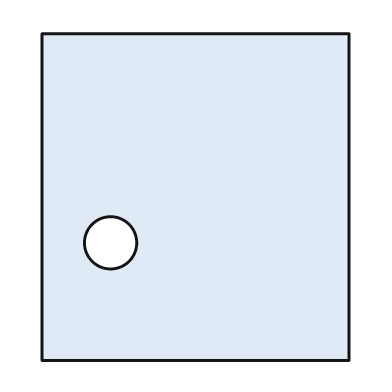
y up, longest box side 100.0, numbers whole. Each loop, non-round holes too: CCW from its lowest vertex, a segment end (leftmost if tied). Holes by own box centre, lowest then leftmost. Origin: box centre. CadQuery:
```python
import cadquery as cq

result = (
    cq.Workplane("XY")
    .moveTo(-47.0, -50.0)
    .lineTo(47.0, -50.0)
    .lineTo(47.0, 50.0)
    .lineTo(-47.0, 50.0)
    .close()
    .moveTo(-26.0, -14.0)
    .circle(8.0)
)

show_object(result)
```